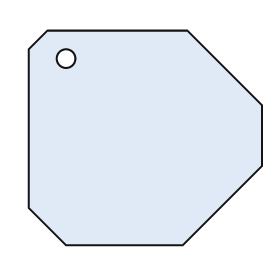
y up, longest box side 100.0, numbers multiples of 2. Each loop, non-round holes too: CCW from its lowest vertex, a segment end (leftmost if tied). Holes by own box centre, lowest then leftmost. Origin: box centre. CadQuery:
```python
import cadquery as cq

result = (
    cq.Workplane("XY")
    .moveTo(-34.0, -46.0)
    .lineTo(16.0, -46.0)
    .lineTo(50.0, -12.0)
    .lineTo(50.0, 14.0)
    .lineTo(18.0, 46.0)
    .lineTo(-42.0, 46.0)
    .lineTo(-50.0, 38.0)
    .lineTo(-50.0, -30.0)
    .close()
    .moveTo(-34.0, 34.0)
    .circle(4.0)
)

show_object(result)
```